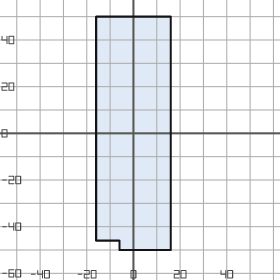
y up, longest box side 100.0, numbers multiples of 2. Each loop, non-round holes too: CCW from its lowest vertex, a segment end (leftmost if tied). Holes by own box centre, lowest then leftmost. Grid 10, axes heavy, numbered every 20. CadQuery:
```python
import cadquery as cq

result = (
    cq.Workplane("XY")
    .moveTo(-6.0, -50.0)
    .lineTo(16.0, -50.0)
    .lineTo(16.0, 50.0)
    .lineTo(-16.0, 50.0)
    .lineTo(-16.0, -46.0)
    .lineTo(-6.0, -46.0)
    .close()
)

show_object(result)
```